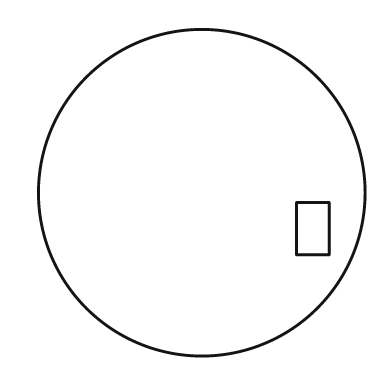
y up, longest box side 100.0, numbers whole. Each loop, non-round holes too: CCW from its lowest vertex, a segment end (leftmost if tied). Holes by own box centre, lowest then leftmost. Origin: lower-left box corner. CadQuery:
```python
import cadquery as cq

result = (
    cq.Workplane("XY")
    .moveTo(50.0, 50.0)
    .circle(50.0)
    .moveTo(79.0, 31.0)
    .lineTo(89.0, 31.0)
    .lineTo(89.0, 47.0)
    .lineTo(79.0, 47.0)
    .close()
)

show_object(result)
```